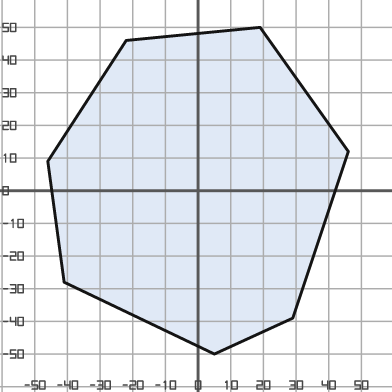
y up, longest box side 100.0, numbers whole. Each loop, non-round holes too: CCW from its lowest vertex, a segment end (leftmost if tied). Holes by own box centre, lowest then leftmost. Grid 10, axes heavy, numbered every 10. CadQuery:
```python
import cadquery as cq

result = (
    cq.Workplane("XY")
    .moveTo(5.0, -50.0)
    .lineTo(29.0, -39.0)
    .lineTo(46.0, 12.0)
    .lineTo(19.0, 50.0)
    .lineTo(-22.0, 46.0)
    .lineTo(-46.0, 9.0)
    .lineTo(-41.0, -28.0)
    .close()
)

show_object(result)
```